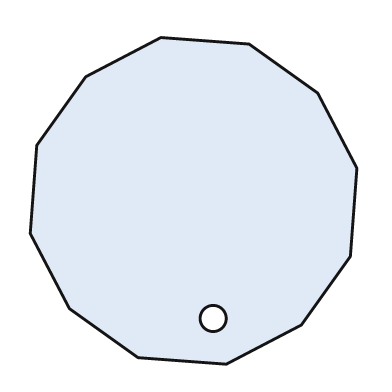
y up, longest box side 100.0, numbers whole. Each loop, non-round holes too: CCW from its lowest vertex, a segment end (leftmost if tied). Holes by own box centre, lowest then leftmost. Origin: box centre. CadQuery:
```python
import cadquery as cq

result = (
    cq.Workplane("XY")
    .moveTo(10.0, -50.0)
    .lineTo(33.0, -38.0)
    .lineTo(48.0, -17.0)
    .lineTo(50.0, 10.0)
    .lineTo(38.0, 33.0)
    .lineTo(17.0, 48.0)
    .lineTo(-10.0, 50.0)
    .lineTo(-33.0, 38.0)
    .lineTo(-48.0, 17.0)
    .lineTo(-50.0, -10.0)
    .lineTo(-38.0, -33.0)
    .lineTo(-17.0, -48.0)
    .close()
    .moveTo(6.0, -36.0)
    .circle(4.0)
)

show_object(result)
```